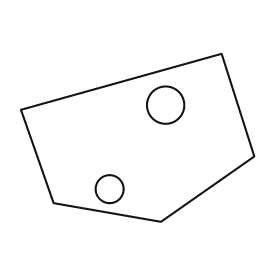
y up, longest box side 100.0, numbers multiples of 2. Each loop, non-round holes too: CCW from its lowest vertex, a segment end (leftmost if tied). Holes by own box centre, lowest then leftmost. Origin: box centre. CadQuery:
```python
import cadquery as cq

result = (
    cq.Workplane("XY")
    .moveTo(10.0, -36.0)
    .lineTo(50.0, -8.0)
    .lineTo(36.0, 36.0)
    .lineTo(-50.0, 12.0)
    .lineTo(-36.0, -28.0)
    .close()
    .moveTo(-12.0, -22.0)
    .circle(6.0)
    .moveTo(12.0, 14.0)
    .circle(8.0)
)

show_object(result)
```